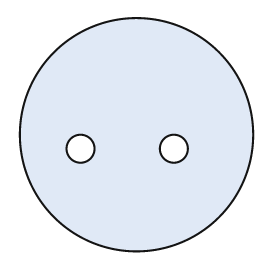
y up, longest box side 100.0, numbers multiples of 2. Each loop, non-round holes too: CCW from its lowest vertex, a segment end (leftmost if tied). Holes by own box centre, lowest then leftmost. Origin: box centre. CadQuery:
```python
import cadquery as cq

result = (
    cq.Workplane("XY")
    .moveTo(0.0, 0.0)
    .circle(50.0)
    .moveTo(-24.0, -6.0)
    .circle(6.0)
    .moveTo(16.0, -6.0)
    .circle(6.0)
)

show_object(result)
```